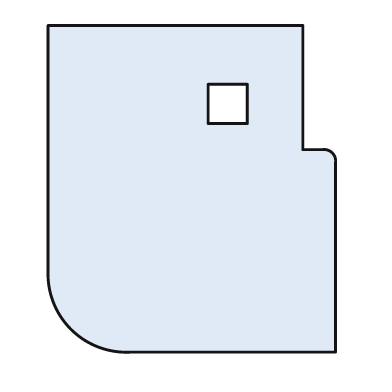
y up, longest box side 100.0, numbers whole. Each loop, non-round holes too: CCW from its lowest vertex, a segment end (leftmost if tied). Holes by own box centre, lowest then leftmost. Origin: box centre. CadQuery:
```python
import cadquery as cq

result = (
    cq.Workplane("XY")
    .moveTo(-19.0, -50.0)
    .lineTo(44.0, -50.0)
    .lineTo(44.0, 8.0)
    .threePointArc((43.0, 11.0), (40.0, 12.0))
    .lineTo(34.0, 12.0)
    .lineTo(34.0, 50.0)
    .lineTo(-44.0, 50.0)
    .lineTo(-44.0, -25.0)
    .threePointArc((-37.0, -43.0), (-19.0, -50.0))
    .close()
    .moveTo(5.0, 20.0)
    .lineTo(17.0, 20.0)
    .lineTo(17.0, 32.0)
    .lineTo(5.0, 32.0)
    .close()
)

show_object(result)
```